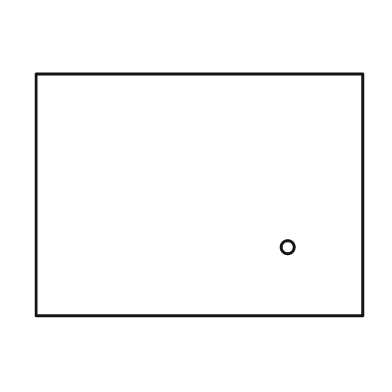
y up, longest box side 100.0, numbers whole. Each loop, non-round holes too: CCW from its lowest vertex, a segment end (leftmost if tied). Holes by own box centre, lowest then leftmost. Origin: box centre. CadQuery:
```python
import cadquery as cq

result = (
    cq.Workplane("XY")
    .moveTo(-50.0, -37.0)
    .lineTo(50.0, -37.0)
    .lineTo(50.0, 37.0)
    .lineTo(-50.0, 37.0)
    .close()
    .moveTo(27.0, -16.0)
    .circle(2.0)
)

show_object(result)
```